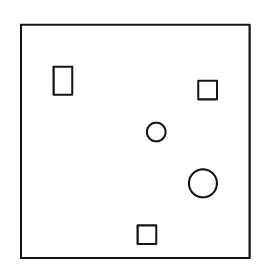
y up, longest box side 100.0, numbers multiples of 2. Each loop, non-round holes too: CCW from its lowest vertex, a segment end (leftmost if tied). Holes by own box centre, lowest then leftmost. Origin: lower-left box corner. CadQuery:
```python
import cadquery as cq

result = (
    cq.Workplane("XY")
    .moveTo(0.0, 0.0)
    .lineTo(98.0, 0.0)
    .lineTo(98.0, 100.0)
    .lineTo(0.0, 100.0)
    .close()
    .moveTo(50.0, 6.0)
    .lineTo(58.0, 6.0)
    .lineTo(58.0, 14.0)
    .lineTo(50.0, 14.0)
    .close()
    .moveTo(78.0, 32.0)
    .circle(6.0)
    .moveTo(58.0, 54.0)
    .circle(4.0)
    .moveTo(76.0, 68.0)
    .lineTo(84.0, 68.0)
    .lineTo(84.0, 76.0)
    .lineTo(76.0, 76.0)
    .close()
    .moveTo(14.0, 70.0)
    .lineTo(22.0, 70.0)
    .lineTo(22.0, 82.0)
    .lineTo(14.0, 82.0)
    .close()
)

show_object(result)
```